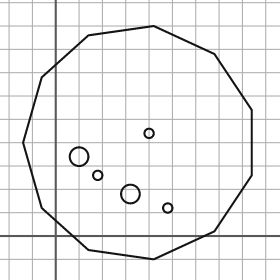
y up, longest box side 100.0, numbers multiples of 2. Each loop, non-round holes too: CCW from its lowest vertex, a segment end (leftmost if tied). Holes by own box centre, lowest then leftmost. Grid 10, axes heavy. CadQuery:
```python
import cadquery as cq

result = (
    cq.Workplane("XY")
    .moveTo(42.0, -10.0)
    .lineTo(68.0, 2.0)
    .lineTo(84.0, 26.0)
    .lineTo(84.0, 54.0)
    .lineTo(68.0, 78.0)
    .lineTo(42.0, 90.0)
    .lineTo(14.0, 86.0)
    .lineTo(-6.0, 68.0)
    .lineTo(-14.0, 40.0)
    .lineTo(-6.0, 12.0)
    .lineTo(14.0, -6.0)
    .close()
    .moveTo(48.0, 12.0)
    .circle(2.0)
    .moveTo(32.0, 18.0)
    .circle(4.0)
    .moveTo(18.0, 26.0)
    .circle(2.0)
    .moveTo(10.0, 34.0)
    .circle(4.0)
    .moveTo(40.0, 44.0)
    .circle(2.0)
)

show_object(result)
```